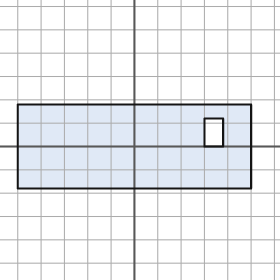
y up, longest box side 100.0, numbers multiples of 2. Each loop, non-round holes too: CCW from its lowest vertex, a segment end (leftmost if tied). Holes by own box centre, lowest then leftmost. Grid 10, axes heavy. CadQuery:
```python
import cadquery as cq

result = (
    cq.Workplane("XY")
    .moveTo(-50.0, -18.0)
    .lineTo(50.0, -18.0)
    .lineTo(50.0, 18.0)
    .lineTo(-50.0, 18.0)
    .close()
    .moveTo(30.0, 0.0)
    .lineTo(38.0, 0.0)
    .lineTo(38.0, 12.0)
    .lineTo(30.0, 12.0)
    .close()
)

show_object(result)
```